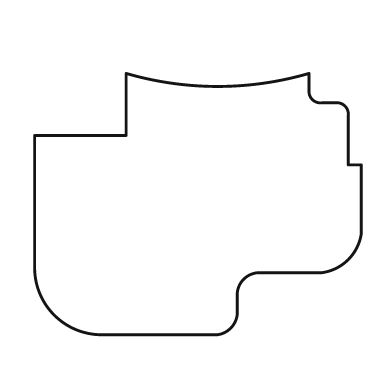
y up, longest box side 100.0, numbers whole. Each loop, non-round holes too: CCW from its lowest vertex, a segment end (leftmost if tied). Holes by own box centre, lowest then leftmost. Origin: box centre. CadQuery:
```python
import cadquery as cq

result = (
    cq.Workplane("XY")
    .moveTo(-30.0, -40.0)
    .lineTo(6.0, -40.0)
    .threePointArc((10.0, -38.0), (12.0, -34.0))
    .lineTo(12.0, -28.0)
    .threePointArc((14.0, -23.0), (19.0, -21.0))
    .lineTo(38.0, -21.0)
    .threePointArc((46.0, -17.0), (50.0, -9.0))
    .lineTo(50.0, 12.0)
    .lineTo(46.0, 12.0)
    .lineTo(46.0, 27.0)
    .threePointArc((45.0, 30.0), (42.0, 31.0))
    .lineTo(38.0, 31.0)
    .threePointArc((35.0, 32.0), (34.0, 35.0))
    .lineTo(34.0, 40.0)
    .threePointArc((6.0, 36.0), (-22.0, 40.0))
    .lineTo(-22.0, 21.0)
    .lineTo(-50.0, 21.0)
    .lineTo(-50.0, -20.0)
    .threePointArc((-44.0, -34.0), (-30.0, -40.0))
    .close()
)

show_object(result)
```